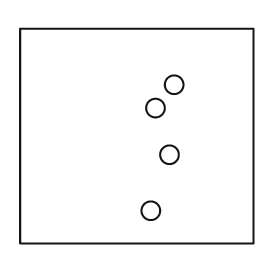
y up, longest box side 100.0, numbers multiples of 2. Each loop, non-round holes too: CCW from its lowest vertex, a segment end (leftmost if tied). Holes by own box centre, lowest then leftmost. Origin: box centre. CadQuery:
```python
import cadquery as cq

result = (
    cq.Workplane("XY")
    .moveTo(-50.0, -46.0)
    .lineTo(50.0, -46.0)
    .lineTo(50.0, 46.0)
    .lineTo(-50.0, 46.0)
    .close()
    .moveTo(6.0, -32.0)
    .circle(4.0)
    .moveTo(14.0, -8.0)
    .circle(4.0)
    .moveTo(8.0, 12.0)
    .circle(4.0)
    .moveTo(16.0, 22.0)
    .circle(4.0)
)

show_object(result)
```